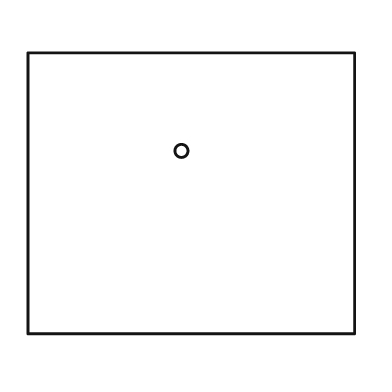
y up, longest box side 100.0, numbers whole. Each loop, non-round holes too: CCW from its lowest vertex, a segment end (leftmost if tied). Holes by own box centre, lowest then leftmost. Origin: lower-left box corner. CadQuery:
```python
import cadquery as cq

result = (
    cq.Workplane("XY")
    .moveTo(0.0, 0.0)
    .lineTo(100.0, 0.0)
    .lineTo(100.0, 86.0)
    .lineTo(0.0, 86.0)
    .close()
    .moveTo(47.0, 56.0)
    .circle(2.0)
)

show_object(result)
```